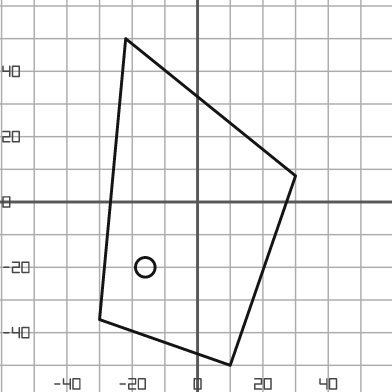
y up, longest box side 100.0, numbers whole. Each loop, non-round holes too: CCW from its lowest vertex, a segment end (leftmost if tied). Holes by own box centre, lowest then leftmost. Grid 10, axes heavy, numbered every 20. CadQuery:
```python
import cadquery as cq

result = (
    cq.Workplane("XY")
    .moveTo(10.0, -50.0)
    .lineTo(30.0, 8.0)
    .lineTo(-22.0, 50.0)
    .lineTo(-30.0, -36.0)
    .close()
    .moveTo(-16.0, -20.0)
    .circle(3.0)
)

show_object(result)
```